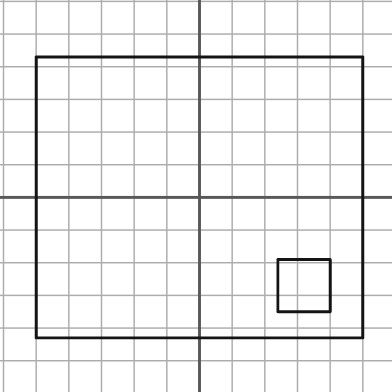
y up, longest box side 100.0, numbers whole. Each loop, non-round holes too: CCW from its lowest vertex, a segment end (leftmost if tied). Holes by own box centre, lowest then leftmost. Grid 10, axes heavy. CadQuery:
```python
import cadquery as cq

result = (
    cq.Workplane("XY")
    .moveTo(-50.0, -43.0)
    .lineTo(50.0, -43.0)
    .lineTo(50.0, 43.0)
    .lineTo(-50.0, 43.0)
    .close()
    .moveTo(24.0, -35.0)
    .lineTo(40.0, -35.0)
    .lineTo(40.0, -19.0)
    .lineTo(24.0, -19.0)
    .close()
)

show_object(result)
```